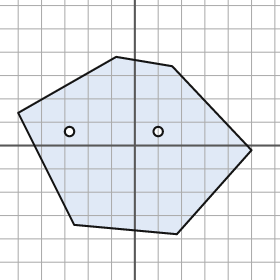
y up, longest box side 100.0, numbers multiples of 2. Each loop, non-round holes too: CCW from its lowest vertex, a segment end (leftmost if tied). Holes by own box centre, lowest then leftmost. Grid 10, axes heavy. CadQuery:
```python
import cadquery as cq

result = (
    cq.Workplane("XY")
    .moveTo(18.0, -38.0)
    .lineTo(50.0, -2.0)
    .lineTo(16.0, 34.0)
    .lineTo(-8.0, 38.0)
    .lineTo(-50.0, 14.0)
    .lineTo(-26.0, -34.0)
    .close()
    .moveTo(-28.0, 6.0)
    .circle(2.0)
    .moveTo(10.0, 6.0)
    .circle(2.0)
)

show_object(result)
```